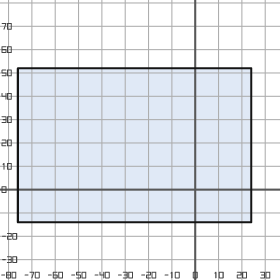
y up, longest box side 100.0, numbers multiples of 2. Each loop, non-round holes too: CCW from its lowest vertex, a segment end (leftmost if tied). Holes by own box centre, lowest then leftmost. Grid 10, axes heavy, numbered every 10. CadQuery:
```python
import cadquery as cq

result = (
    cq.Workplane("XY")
    .moveTo(-76.0, -14.0)
    .lineTo(24.0, -14.0)
    .lineTo(24.0, 52.0)
    .lineTo(-76.0, 52.0)
    .close()
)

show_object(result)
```